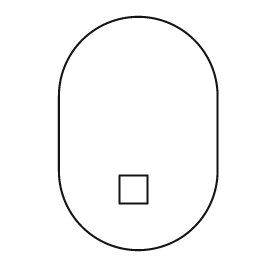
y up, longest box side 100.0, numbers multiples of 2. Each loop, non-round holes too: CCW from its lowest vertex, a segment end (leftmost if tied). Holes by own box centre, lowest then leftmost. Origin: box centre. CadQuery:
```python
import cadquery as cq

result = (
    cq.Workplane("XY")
    .moveTo(-34.0, -16.0)
    .threePointArc((0.0, -50.0), (34.0, -16.0))
    .lineTo(34.0, 16.0)
    .threePointArc((0.0, 50.0), (-34.0, 16.0))
    .close()
    .moveTo(-8.0, -30.0)
    .lineTo(4.0, -30.0)
    .lineTo(4.0, -18.0)
    .lineTo(-8.0, -18.0)
    .close()
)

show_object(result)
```